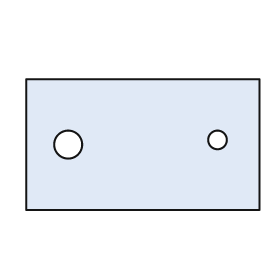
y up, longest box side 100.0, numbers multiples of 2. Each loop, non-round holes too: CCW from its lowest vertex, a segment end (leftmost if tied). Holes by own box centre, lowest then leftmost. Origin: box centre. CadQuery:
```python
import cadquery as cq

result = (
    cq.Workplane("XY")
    .moveTo(-50.0, -28.0)
    .lineTo(50.0, -28.0)
    .lineTo(50.0, 28.0)
    .lineTo(-50.0, 28.0)
    .close()
    .moveTo(-32.0, 0.0)
    .circle(6.0)
    .moveTo(32.0, 2.0)
    .circle(4.0)
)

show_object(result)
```